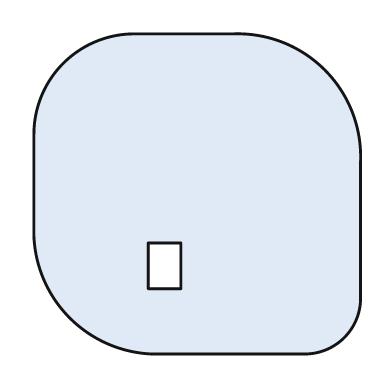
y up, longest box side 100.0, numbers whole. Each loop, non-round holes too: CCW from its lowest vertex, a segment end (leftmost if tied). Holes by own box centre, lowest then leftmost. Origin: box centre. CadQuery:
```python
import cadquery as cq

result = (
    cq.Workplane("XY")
    .moveTo(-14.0, -49.0)
    .lineTo(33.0, -49.0)
    .threePointArc((45.0, -44.0), (50.0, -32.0))
    .lineTo(50.0, 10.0)
    .threePointArc((39.0, 38.0), (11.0, 49.0))
    .lineTo(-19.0, 49.0)
    .threePointArc((-41.0, 40.0), (-50.0, 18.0))
    .lineTo(-50.0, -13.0)
    .threePointArc((-39.0, -38.0), (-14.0, -49.0))
    .close()
    .moveTo(-15.0, -29.0)
    .lineTo(-5.0, -29.0)
    .lineTo(-5.0, -15.0)
    .lineTo(-15.0, -15.0)
    .close()
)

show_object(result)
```